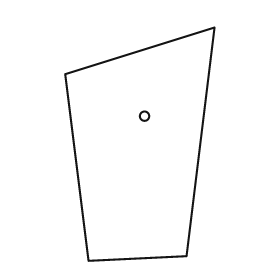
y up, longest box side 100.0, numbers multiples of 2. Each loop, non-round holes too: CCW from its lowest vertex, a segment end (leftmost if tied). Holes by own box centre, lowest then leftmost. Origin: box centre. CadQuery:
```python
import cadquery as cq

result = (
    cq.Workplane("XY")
    .moveTo(-22.0, -50.0)
    .lineTo(20.0, -48.0)
    .lineTo(32.0, 50.0)
    .lineTo(-32.0, 30.0)
    .close()
    .moveTo(2.0, 12.0)
    .circle(2.0)
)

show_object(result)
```